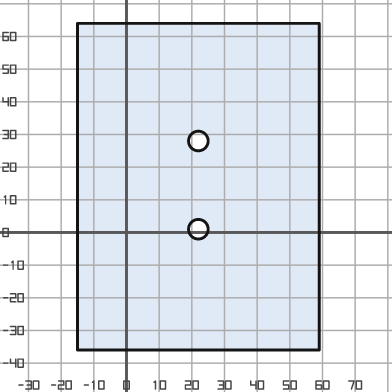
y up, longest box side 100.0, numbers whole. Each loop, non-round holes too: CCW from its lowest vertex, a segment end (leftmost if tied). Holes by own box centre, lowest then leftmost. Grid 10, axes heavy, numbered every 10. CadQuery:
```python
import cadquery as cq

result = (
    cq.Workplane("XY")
    .moveTo(-15.0, -36.0)
    .lineTo(59.0, -36.0)
    .lineTo(59.0, 64.0)
    .lineTo(-15.0, 64.0)
    .close()
    .moveTo(22.0, 1.0)
    .circle(3.0)
    .moveTo(22.0, 28.0)
    .circle(3.0)
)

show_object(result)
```